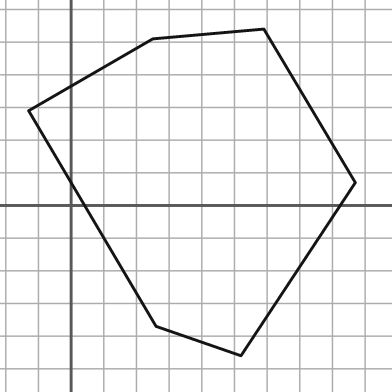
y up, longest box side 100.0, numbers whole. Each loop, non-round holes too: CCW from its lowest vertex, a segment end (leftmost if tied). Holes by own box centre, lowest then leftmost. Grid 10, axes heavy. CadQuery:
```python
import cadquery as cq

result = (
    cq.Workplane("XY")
    .moveTo(52.0, -46.0)
    .lineTo(87.0, 7.0)
    .lineTo(59.0, 54.0)
    .lineTo(25.0, 51.0)
    .lineTo(-13.0, 29.0)
    .lineTo(26.0, -37.0)
    .close()
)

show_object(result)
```